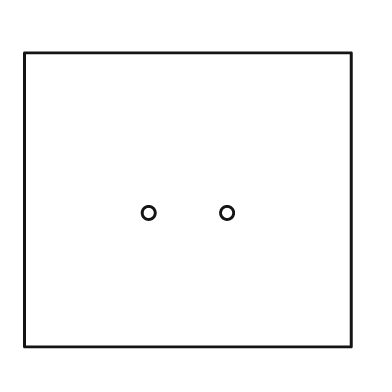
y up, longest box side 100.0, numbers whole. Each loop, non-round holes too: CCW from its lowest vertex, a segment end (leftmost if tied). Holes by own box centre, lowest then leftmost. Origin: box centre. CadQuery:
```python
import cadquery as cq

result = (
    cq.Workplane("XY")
    .moveTo(-50.0, -45.0)
    .lineTo(50.0, -45.0)
    .lineTo(50.0, 45.0)
    .lineTo(-50.0, 45.0)
    .close()
    .moveTo(-12.0, -4.0)
    .circle(2.0)
    .moveTo(12.0, -4.0)
    .circle(2.0)
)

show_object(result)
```